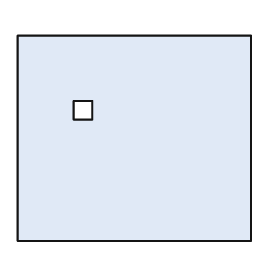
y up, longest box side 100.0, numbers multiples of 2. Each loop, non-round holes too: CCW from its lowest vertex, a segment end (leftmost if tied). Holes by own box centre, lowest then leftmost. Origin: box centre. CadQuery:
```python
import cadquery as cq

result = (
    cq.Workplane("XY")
    .moveTo(-50.0, -44.0)
    .lineTo(50.0, -44.0)
    .lineTo(50.0, 44.0)
    .lineTo(-50.0, 44.0)
    .close()
    .moveTo(-26.0, 8.0)
    .lineTo(-18.0, 8.0)
    .lineTo(-18.0, 16.0)
    .lineTo(-26.0, 16.0)
    .close()
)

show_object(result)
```